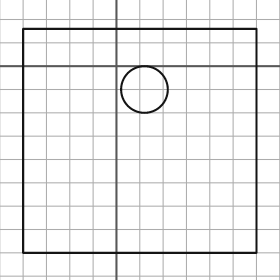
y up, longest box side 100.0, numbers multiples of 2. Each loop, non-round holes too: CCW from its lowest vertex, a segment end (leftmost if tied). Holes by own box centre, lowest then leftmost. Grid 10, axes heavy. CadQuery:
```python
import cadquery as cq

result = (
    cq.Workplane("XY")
    .moveTo(-40.0, -80.0)
    .lineTo(60.0, -80.0)
    .lineTo(60.0, 16.0)
    .lineTo(-40.0, 16.0)
    .close()
    .moveTo(12.0, -10.0)
    .circle(10.0)
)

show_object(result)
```